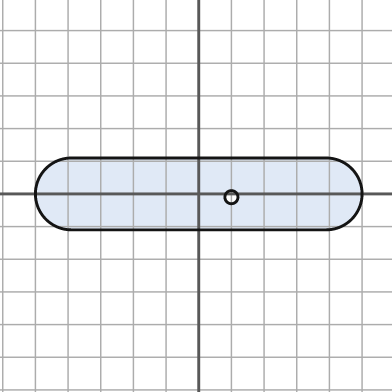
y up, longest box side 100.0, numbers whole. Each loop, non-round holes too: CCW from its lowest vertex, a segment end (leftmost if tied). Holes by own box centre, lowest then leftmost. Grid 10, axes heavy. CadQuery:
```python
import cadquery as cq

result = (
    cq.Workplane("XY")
    .moveTo(-39.0, -11.0)
    .lineTo(39.0, -11.0)
    .threePointArc((50.0, 0.0), (39.0, 11.0))
    .lineTo(-39.0, 11.0)
    .threePointArc((-50.0, 0.0), (-39.0, -11.0))
    .close()
    .moveTo(10.0, -1.0)
    .circle(2.0)
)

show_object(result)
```